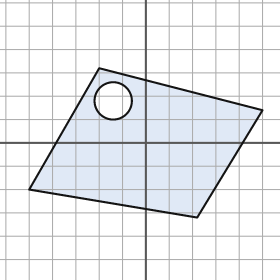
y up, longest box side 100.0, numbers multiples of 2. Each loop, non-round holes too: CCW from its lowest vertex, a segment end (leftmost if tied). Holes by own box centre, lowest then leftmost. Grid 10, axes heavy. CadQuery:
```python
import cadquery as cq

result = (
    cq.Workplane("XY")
    .moveTo(22.0, -32.0)
    .lineTo(50.0, 14.0)
    .lineTo(-20.0, 32.0)
    .lineTo(-50.0, -20.0)
    .close()
    .moveTo(-14.0, 18.0)
    .circle(8.0)
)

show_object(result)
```